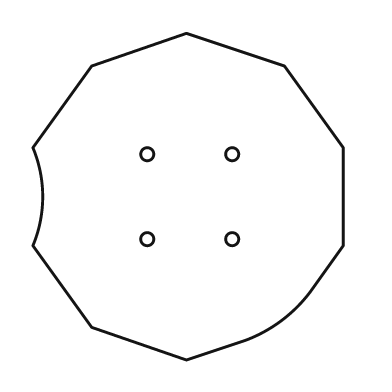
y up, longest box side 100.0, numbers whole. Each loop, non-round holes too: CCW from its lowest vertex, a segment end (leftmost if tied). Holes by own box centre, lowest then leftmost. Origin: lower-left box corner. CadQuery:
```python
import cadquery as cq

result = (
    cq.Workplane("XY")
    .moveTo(47.0, 0.0)
    .lineTo(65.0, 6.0)
    .threePointArc((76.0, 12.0), (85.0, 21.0))
    .lineTo(95.0, 35.0)
    .lineTo(95.0, 65.0)
    .lineTo(77.0, 90.0)
    .lineTo(47.0, 100.0)
    .lineTo(18.0, 90.0)
    .lineTo(0.0, 65.0)
    .threePointArc((3.0, 50.0), (0.0, 35.0))
    .lineTo(18.0, 10.0)
    .close()
    .moveTo(35.0, 37.0)
    .circle(2.0)
    .moveTo(61.0, 37.0)
    .circle(2.0)
    .moveTo(35.0, 63.0)
    .circle(2.0)
    .moveTo(61.0, 63.0)
    .circle(2.0)
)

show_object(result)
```